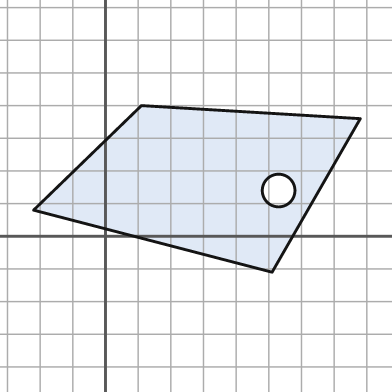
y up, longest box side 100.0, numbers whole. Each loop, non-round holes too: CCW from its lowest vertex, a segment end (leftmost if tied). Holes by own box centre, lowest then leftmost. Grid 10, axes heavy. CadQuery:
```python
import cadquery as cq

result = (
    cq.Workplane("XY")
    .moveTo(51.0, -11.0)
    .lineTo(78.0, 36.0)
    .lineTo(11.0, 40.0)
    .lineTo(-22.0, 8.0)
    .close()
    .moveTo(53.0, 14.0)
    .circle(5.0)
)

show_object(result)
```